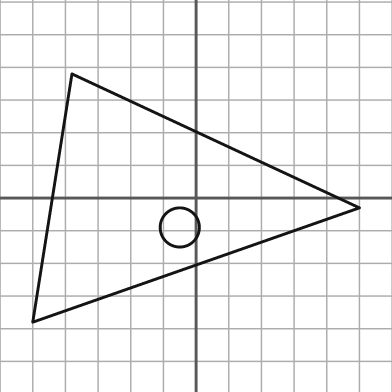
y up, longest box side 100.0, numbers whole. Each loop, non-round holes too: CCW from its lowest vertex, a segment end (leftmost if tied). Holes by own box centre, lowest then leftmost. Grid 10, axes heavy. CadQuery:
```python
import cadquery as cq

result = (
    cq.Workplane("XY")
    .moveTo(-50.0, -38.0)
    .lineTo(50.0, -3.0)
    .lineTo(-38.0, 38.0)
    .close()
    .moveTo(-5.0, -9.0)
    .circle(6.0)
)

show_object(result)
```